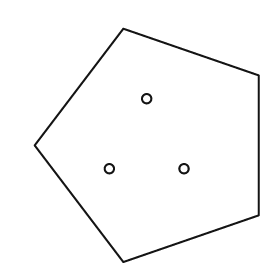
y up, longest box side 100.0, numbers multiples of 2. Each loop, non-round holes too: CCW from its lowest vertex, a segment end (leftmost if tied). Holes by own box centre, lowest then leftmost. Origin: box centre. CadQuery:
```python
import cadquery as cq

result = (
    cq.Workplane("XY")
    .moveTo(-10.0, -50.0)
    .lineTo(48.0, -30.0)
    .lineTo(48.0, 30.0)
    .lineTo(-10.0, 50.0)
    .lineTo(-48.0, 0.0)
    .close()
    .moveTo(-16.0, -10.0)
    .circle(2.0)
    .moveTo(16.0, -10.0)
    .circle(2.0)
    .moveTo(0.0, 20.0)
    .circle(2.0)
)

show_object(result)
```